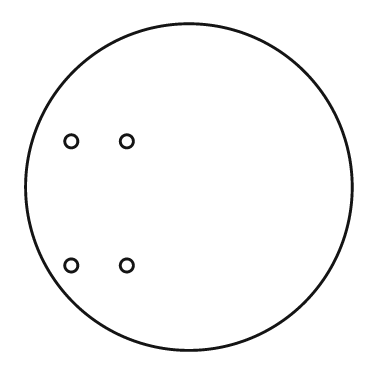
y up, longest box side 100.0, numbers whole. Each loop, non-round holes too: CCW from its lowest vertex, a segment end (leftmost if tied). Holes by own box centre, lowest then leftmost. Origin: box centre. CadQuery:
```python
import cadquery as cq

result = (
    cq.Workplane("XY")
    .moveTo(0.0, 0.0)
    .circle(50.0)
    .moveTo(-36.0, -24.0)
    .circle(2.0)
    .moveTo(-19.0, -24.0)
    .circle(2.0)
    .moveTo(-36.0, 14.0)
    .circle(2.0)
    .moveTo(-19.0, 14.0)
    .circle(2.0)
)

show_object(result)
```